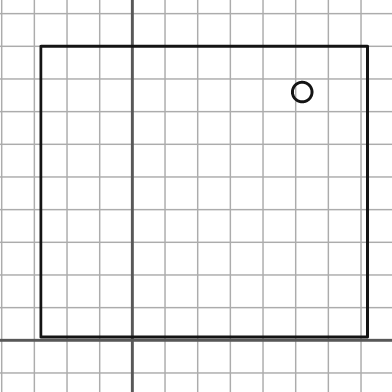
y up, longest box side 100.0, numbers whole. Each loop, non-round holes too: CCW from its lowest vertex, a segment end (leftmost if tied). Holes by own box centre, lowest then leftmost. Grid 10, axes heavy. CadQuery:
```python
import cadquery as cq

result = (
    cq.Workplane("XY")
    .moveTo(-28.0, 1.0)
    .lineTo(72.0, 1.0)
    .lineTo(72.0, 90.0)
    .lineTo(-28.0, 90.0)
    .close()
    .moveTo(52.0, 76.0)
    .circle(3.0)
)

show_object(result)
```